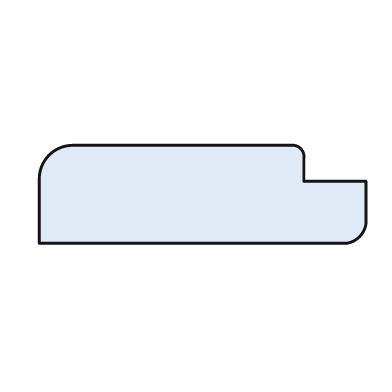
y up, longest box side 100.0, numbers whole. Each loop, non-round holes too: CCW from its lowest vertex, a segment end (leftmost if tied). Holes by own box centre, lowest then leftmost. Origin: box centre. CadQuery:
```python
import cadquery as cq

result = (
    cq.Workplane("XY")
    .moveTo(-50.0, -15.0)
    .lineTo(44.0, -15.0)
    .threePointArc((48.0, -13.0), (50.0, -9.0))
    .lineTo(50.0, 4.0)
    .lineTo(31.0, 4.0)
    .lineTo(31.0, 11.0)
    .threePointArc((30.0, 14.0), (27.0, 15.0))
    .lineTo(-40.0, 15.0)
    .threePointArc((-47.0, 12.0), (-50.0, 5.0))
    .close()
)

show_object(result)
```